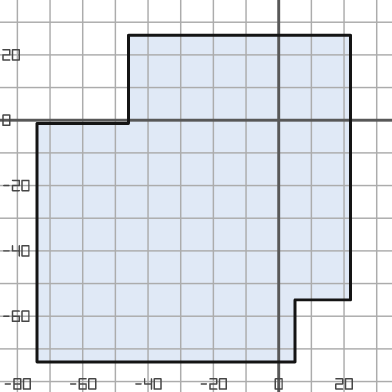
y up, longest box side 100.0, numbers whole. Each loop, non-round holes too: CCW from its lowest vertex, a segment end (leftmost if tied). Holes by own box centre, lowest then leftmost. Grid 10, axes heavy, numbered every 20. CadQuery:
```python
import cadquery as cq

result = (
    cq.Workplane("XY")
    .moveTo(-74.0, -74.0)
    .lineTo(5.0, -74.0)
    .lineTo(5.0, -55.0)
    .lineTo(22.0, -55.0)
    .lineTo(22.0, 26.0)
    .lineTo(-46.0, 26.0)
    .lineTo(-46.0, -1.0)
    .lineTo(-74.0, -1.0)
    .close()
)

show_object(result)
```